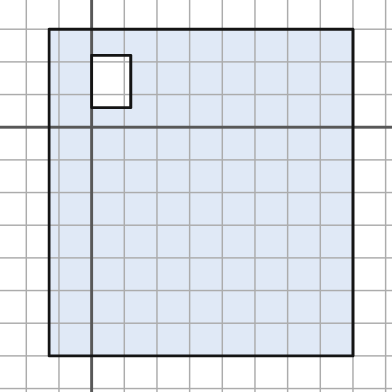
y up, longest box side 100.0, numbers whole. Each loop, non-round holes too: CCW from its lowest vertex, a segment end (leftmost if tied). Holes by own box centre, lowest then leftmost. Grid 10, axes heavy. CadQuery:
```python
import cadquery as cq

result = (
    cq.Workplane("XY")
    .moveTo(-13.0, -70.0)
    .lineTo(80.0, -70.0)
    .lineTo(80.0, 30.0)
    .lineTo(-13.0, 30.0)
    .close()
    .moveTo(0.0, 6.0)
    .lineTo(12.0, 6.0)
    .lineTo(12.0, 22.0)
    .lineTo(0.0, 22.0)
    .close()
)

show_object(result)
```